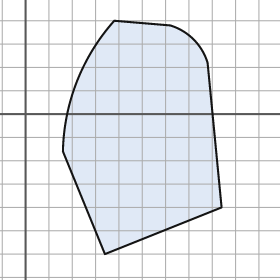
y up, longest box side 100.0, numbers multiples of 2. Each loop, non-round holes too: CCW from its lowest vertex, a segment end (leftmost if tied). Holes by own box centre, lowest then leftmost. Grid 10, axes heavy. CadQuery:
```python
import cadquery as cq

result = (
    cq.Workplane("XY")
    .moveTo(34.0, -60.0)
    .lineTo(84.0, -40.0)
    .lineTo(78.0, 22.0)
    .threePointArc((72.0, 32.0), (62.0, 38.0))
    .lineTo(38.0, 40.0)
    .threePointArc((22.0, 14.0), (16.0, -16.0))
    .close()
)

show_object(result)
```